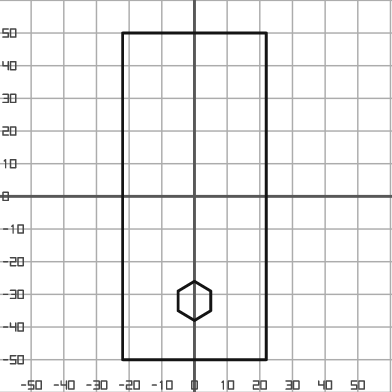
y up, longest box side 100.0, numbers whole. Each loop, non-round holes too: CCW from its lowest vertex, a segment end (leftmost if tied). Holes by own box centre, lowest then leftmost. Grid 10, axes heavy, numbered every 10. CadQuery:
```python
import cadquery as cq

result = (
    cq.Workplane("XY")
    .moveTo(-22.0, -50.0)
    .lineTo(22.0, -50.0)
    .lineTo(22.0, 50.0)
    .lineTo(-22.0, 50.0)
    .close()
    .moveTo(0.0, -38.0)
    .lineTo(5.0, -35.0)
    .lineTo(5.0, -29.0)
    .lineTo(0.0, -26.0)
    .lineTo(-5.0, -29.0)
    .lineTo(-5.0, -35.0)
    .close()
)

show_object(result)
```